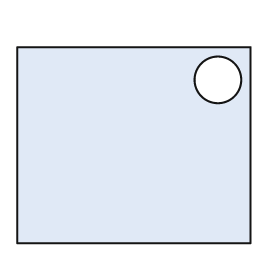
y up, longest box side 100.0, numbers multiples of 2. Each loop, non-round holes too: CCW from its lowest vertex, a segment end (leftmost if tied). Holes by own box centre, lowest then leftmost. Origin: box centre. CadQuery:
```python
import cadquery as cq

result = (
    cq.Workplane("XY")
    .moveTo(-50.0, -42.0)
    .lineTo(50.0, -42.0)
    .lineTo(50.0, 42.0)
    .lineTo(-50.0, 42.0)
    .close()
    .moveTo(36.0, 28.0)
    .circle(10.0)
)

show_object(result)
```